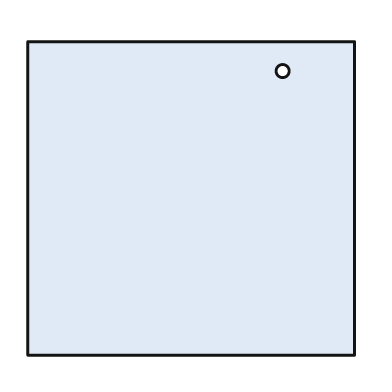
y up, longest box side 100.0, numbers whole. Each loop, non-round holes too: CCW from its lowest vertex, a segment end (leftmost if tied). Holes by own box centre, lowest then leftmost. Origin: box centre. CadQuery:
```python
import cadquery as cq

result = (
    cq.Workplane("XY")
    .moveTo(-50.0, -48.0)
    .lineTo(50.0, -48.0)
    .lineTo(50.0, 48.0)
    .lineTo(-50.0, 48.0)
    .close()
    .moveTo(28.0, 39.0)
    .circle(2.0)
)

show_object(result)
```